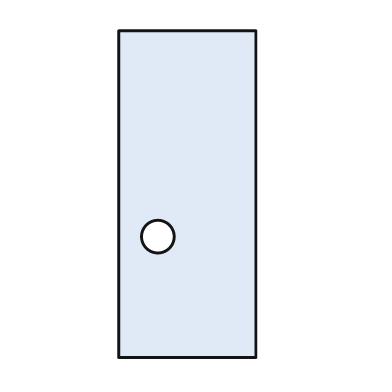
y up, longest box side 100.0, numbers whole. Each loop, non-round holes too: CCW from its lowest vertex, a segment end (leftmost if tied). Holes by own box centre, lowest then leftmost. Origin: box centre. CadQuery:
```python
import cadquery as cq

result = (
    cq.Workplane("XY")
    .moveTo(-21.0, -50.0)
    .lineTo(21.0, -50.0)
    .lineTo(21.0, 50.0)
    .lineTo(-21.0, 50.0)
    .close()
    .moveTo(-9.0, -13.0)
    .circle(5.0)
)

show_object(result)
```